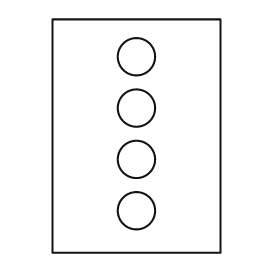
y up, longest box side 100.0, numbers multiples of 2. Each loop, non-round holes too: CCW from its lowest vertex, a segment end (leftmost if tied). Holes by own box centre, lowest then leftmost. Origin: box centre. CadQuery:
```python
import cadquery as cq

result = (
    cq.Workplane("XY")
    .moveTo(-36.0, -50.0)
    .lineTo(36.0, -50.0)
    .lineTo(36.0, 50.0)
    .lineTo(-36.0, 50.0)
    .close()
    .moveTo(0.0, -32.0)
    .circle(8.0)
    .moveTo(0.0, -10.0)
    .circle(8.0)
    .moveTo(0.0, 12.0)
    .circle(8.0)
    .moveTo(0.0, 34.0)
    .circle(8.0)
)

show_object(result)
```